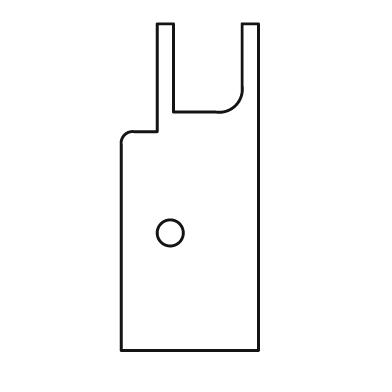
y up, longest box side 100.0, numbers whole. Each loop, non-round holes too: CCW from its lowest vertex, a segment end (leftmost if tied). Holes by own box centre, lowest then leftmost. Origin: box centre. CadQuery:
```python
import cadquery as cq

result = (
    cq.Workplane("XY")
    .moveTo(-21.0, -50.0)
    .lineTo(21.0, -50.0)
    .lineTo(21.0, 50.0)
    .lineTo(16.0, 50.0)
    .lineTo(16.0, 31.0)
    .threePointArc((14.0, 25.0), (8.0, 23.0))
    .lineTo(-5.0, 23.0)
    .lineTo(-5.0, 50.0)
    .lineTo(-10.0, 50.0)
    .lineTo(-10.0, 17.0)
    .lineTo(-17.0, 17.0)
    .threePointArc((-20.0, 16.0), (-21.0, 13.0))
    .close()
    .moveTo(-6.0, -14.0)
    .circle(4.0)
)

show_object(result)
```